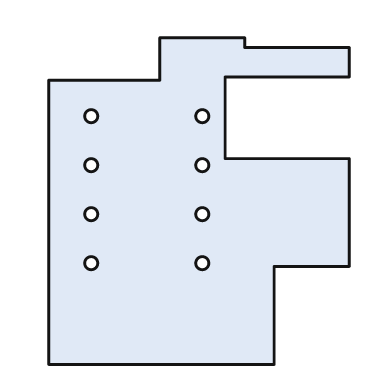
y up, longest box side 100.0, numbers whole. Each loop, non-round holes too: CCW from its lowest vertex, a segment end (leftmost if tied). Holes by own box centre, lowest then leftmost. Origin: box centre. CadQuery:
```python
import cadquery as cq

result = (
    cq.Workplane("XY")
    .moveTo(-46.0, -50.0)
    .lineTo(23.0, -50.0)
    .lineTo(23.0, -20.0)
    .lineTo(46.0, -20.0)
    .lineTo(46.0, 13.0)
    .lineTo(8.0, 13.0)
    .lineTo(8.0, 38.0)
    .lineTo(46.0, 38.0)
    .lineTo(46.0, 47.0)
    .lineTo(14.0, 47.0)
    .lineTo(14.0, 50.0)
    .lineTo(-12.0, 50.0)
    .lineTo(-12.0, 37.0)
    .lineTo(-46.0, 37.0)
    .close()
    .moveTo(-33.0, -19.0)
    .circle(2.0)
    .moveTo(1.0, -19.0)
    .circle(2.0)
    .moveTo(-33.0, -4.0)
    .circle(2.0)
    .moveTo(1.0, -4.0)
    .circle(2.0)
    .moveTo(-33.0, 11.0)
    .circle(2.0)
    .moveTo(1.0, 11.0)
    .circle(2.0)
    .moveTo(-33.0, 26.0)
    .circle(2.0)
    .moveTo(1.0, 26.0)
    .circle(2.0)
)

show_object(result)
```